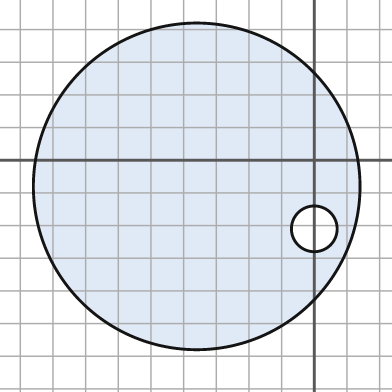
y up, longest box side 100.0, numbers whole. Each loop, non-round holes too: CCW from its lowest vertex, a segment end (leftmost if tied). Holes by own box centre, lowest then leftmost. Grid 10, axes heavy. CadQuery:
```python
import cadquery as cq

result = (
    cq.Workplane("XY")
    .moveTo(-36.0, -8.0)
    .circle(50.0)
    .moveTo(0.0, -21.0)
    .circle(7.0)
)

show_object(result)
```